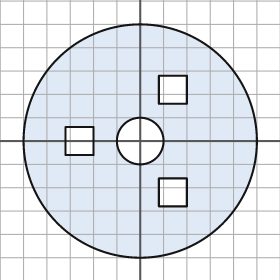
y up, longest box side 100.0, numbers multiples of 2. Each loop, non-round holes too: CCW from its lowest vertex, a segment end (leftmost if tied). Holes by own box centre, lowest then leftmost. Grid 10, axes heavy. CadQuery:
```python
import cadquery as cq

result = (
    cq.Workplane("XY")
    .moveTo(0.0, 0.0)
    .circle(50.0)
    .moveTo(8.0, -28.0)
    .lineTo(20.0, -28.0)
    .lineTo(20.0, -16.0)
    .lineTo(8.0, -16.0)
    .close()
    .moveTo(-32.0, -6.0)
    .lineTo(-20.0, -6.0)
    .lineTo(-20.0, 6.0)
    .lineTo(-32.0, 6.0)
    .close()
    .moveTo(0.0, 0.0)
    .circle(10.0)
    .moveTo(8.0, 16.0)
    .lineTo(20.0, 16.0)
    .lineTo(20.0, 28.0)
    .lineTo(8.0, 28.0)
    .close()
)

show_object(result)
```